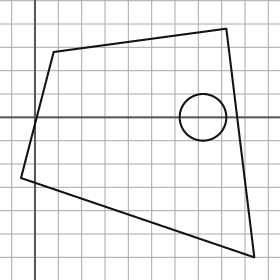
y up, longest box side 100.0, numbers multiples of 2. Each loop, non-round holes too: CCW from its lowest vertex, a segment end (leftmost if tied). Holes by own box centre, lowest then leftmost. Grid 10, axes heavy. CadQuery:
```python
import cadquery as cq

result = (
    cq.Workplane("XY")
    .moveTo(94.0, -60.0)
    .lineTo(82.0, 38.0)
    .lineTo(8.0, 28.0)
    .lineTo(-6.0, -26.0)
    .close()
    .moveTo(72.0, 0.0)
    .circle(10.0)
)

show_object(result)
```